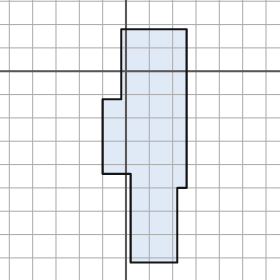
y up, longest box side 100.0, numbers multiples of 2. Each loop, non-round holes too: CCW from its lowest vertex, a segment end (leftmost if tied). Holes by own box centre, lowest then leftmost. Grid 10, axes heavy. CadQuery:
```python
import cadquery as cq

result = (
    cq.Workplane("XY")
    .moveTo(2.0, -82.0)
    .lineTo(22.0, -82.0)
    .lineTo(22.0, -50.0)
    .lineTo(26.0, -50.0)
    .lineTo(26.0, 18.0)
    .lineTo(-2.0, 18.0)
    .lineTo(-2.0, -12.0)
    .lineTo(-10.0, -12.0)
    .lineTo(-10.0, -44.0)
    .lineTo(2.0, -44.0)
    .close()
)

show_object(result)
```